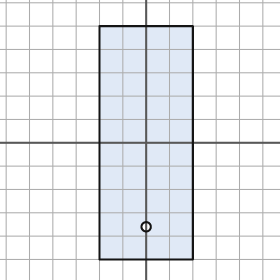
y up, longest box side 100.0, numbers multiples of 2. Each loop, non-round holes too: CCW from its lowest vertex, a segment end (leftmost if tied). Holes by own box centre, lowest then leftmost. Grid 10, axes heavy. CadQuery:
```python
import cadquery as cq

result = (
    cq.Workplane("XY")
    .moveTo(-20.0, -50.0)
    .lineTo(20.0, -50.0)
    .lineTo(20.0, 50.0)
    .lineTo(-20.0, 50.0)
    .close()
    .moveTo(0.0, -36.0)
    .circle(2.0)
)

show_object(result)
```